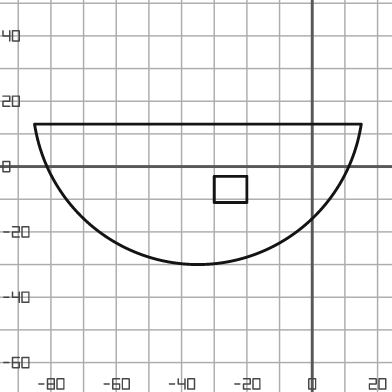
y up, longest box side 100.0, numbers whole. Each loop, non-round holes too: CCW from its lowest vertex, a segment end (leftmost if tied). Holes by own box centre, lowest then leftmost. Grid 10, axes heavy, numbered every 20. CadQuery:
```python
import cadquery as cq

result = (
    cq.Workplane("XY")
    .moveTo(-85.0, 13.0)
    .threePointArc((-35.0, -30.0), (15.0, 13.0))
    .close()
    .moveTo(-30.0, -11.0)
    .lineTo(-20.0, -11.0)
    .lineTo(-20.0, -3.0)
    .lineTo(-30.0, -3.0)
    .close()
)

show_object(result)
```